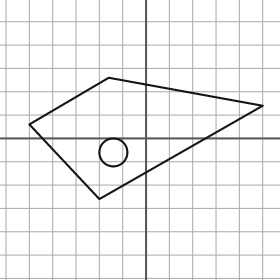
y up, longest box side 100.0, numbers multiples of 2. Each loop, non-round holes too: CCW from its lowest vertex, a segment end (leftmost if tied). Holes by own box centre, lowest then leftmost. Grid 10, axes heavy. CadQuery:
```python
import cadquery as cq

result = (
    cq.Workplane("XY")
    .moveTo(-20.0, -26.0)
    .lineTo(50.0, 14.0)
    .lineTo(-16.0, 26.0)
    .lineTo(-50.0, 6.0)
    .close()
    .moveTo(-14.0, -6.0)
    .circle(6.0)
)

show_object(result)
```